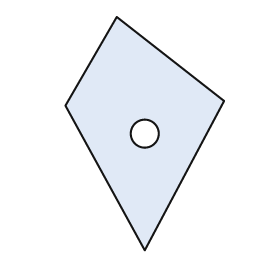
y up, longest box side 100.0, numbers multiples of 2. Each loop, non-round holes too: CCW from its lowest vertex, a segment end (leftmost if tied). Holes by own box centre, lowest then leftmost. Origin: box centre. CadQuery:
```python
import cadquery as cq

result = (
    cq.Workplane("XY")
    .moveTo(0.0, -50.0)
    .lineTo(34.0, 14.0)
    .lineTo(-12.0, 50.0)
    .lineTo(-34.0, 12.0)
    .close()
    .moveTo(0.0, 0.0)
    .circle(6.0)
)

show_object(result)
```